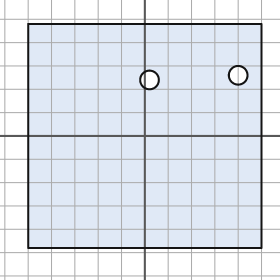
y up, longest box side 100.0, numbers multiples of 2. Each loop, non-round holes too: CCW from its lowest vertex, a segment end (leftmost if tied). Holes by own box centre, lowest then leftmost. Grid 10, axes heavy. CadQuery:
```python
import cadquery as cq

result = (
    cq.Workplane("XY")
    .moveTo(-50.0, -48.0)
    .lineTo(50.0, -48.0)
    .lineTo(50.0, 48.0)
    .lineTo(-50.0, 48.0)
    .close()
    .moveTo(2.0, 24.0)
    .circle(4.0)
    .moveTo(40.0, 26.0)
    .circle(4.0)
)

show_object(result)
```